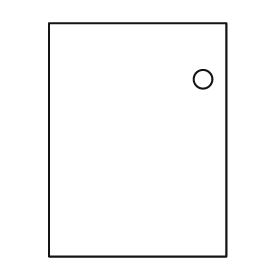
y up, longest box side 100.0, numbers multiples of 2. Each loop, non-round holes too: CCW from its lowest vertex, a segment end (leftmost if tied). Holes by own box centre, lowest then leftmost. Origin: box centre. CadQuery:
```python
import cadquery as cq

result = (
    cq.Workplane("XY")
    .moveTo(-38.0, -50.0)
    .lineTo(38.0, -50.0)
    .lineTo(38.0, 50.0)
    .lineTo(-38.0, 50.0)
    .close()
    .moveTo(28.0, 26.0)
    .circle(4.0)
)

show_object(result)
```